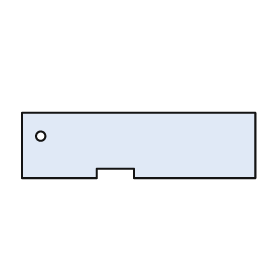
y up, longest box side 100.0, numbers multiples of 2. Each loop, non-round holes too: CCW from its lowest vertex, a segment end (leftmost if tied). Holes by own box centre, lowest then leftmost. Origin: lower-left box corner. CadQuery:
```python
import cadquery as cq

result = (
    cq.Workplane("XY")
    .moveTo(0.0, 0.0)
    .lineTo(32.0, 0.0)
    .lineTo(32.0, 4.0)
    .lineTo(48.0, 4.0)
    .lineTo(48.0, 0.0)
    .lineTo(100.0, 0.0)
    .lineTo(100.0, 28.0)
    .lineTo(0.0, 28.0)
    .close()
    .moveTo(8.0, 18.0)
    .circle(2.0)
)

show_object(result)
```